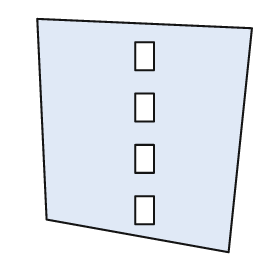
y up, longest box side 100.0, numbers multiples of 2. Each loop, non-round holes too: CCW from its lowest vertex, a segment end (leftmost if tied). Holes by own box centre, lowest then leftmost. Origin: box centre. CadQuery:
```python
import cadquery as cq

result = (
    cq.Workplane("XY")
    .moveTo(36.0, -50.0)
    .lineTo(46.0, 46.0)
    .lineTo(-46.0, 50.0)
    .lineTo(-42.0, -36.0)
    .close()
    .moveTo(-4.0, -38.0)
    .lineTo(4.0, -38.0)
    .lineTo(4.0, -26.0)
    .lineTo(-4.0, -26.0)
    .close()
    .moveTo(-4.0, -16.0)
    .lineTo(4.0, -16.0)
    .lineTo(4.0, -4.0)
    .lineTo(-4.0, -4.0)
    .close()
    .moveTo(-4.0, 6.0)
    .lineTo(4.0, 6.0)
    .lineTo(4.0, 18.0)
    .lineTo(-4.0, 18.0)
    .close()
    .moveTo(-4.0, 28.0)
    .lineTo(4.0, 28.0)
    .lineTo(4.0, 40.0)
    .lineTo(-4.0, 40.0)
    .close()
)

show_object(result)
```